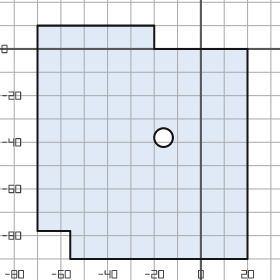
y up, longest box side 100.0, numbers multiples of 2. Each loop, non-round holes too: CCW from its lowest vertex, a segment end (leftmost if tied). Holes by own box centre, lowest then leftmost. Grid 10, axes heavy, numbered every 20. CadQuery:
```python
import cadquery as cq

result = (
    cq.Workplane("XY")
    .moveTo(-56.0, -90.0)
    .lineTo(20.0, -90.0)
    .lineTo(20.0, 0.0)
    .lineTo(-20.0, 0.0)
    .lineTo(-20.0, 10.0)
    .lineTo(-70.0, 10.0)
    .lineTo(-70.0, -78.0)
    .lineTo(-56.0, -78.0)
    .close()
    .moveTo(-16.0, -38.0)
    .circle(4.0)
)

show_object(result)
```